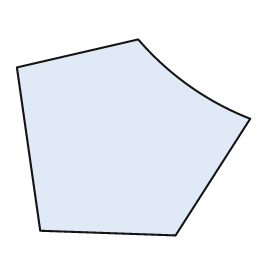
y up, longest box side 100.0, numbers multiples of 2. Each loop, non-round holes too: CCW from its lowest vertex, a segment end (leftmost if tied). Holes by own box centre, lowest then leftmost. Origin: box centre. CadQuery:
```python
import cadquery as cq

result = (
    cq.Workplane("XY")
    .moveTo(18.0, -42.0)
    .lineTo(50.0, 8.0)
    .threePointArc((24.0, 22.0), (2.0, 42.0))
    .lineTo(-50.0, 30.0)
    .lineTo(-40.0, -40.0)
    .close()
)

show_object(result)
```